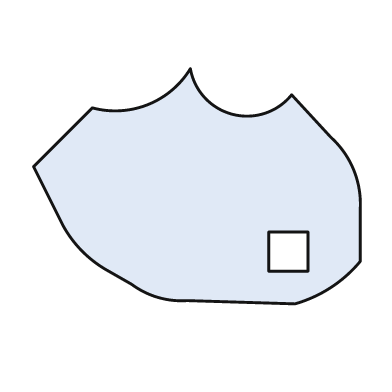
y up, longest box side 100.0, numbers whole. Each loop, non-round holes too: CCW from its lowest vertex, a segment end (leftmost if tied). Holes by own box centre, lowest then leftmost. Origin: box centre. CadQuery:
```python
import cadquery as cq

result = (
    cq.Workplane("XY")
    .moveTo(30.0, -36.0)
    .threePointArc((41.0, -31.0), (50.0, -23.0))
    .lineTo(50.0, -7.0)
    .threePointArc((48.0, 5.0), (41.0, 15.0))
    .lineTo(29.0, 28.0)
    .threePointArc((11.0, 22.0), (-2.0, 36.0))
    .threePointArc((-15.0, 25.0), (-32.0, 24.0))
    .lineTo(-50.0, 6.0)
    .lineTo(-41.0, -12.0)
    .threePointArc((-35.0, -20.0), (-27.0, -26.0))
    .lineTo(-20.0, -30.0)
    .threePointArc((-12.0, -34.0), (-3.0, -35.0))
    .close()
    .moveTo(22.0, -26.0)
    .lineTo(34.0, -26.0)
    .lineTo(34.0, -14.0)
    .lineTo(22.0, -14.0)
    .close()
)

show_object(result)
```